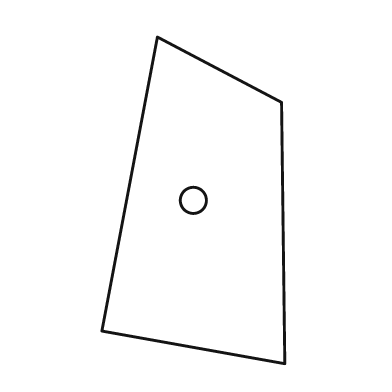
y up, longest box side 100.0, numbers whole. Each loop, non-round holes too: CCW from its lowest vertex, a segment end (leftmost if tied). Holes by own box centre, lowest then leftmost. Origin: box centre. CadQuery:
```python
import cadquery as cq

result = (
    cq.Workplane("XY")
    .moveTo(28.0, -50.0)
    .lineTo(27.0, 30.0)
    .lineTo(-11.0, 50.0)
    .lineTo(-28.0, -40.0)
    .close()
    .moveTo(0.0, 0.0)
    .circle(4.0)
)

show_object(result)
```